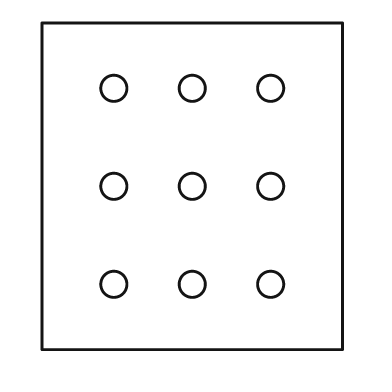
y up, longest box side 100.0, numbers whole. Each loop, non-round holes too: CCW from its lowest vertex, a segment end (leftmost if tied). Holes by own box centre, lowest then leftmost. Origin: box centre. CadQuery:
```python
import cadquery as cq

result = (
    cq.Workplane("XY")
    .moveTo(-46.0, -50.0)
    .lineTo(46.0, -50.0)
    .lineTo(46.0, 50.0)
    .lineTo(-46.0, 50.0)
    .close()
    .moveTo(-24.0, -30.0)
    .circle(4.0)
    .moveTo(0.0, -30.0)
    .circle(4.0)
    .moveTo(24.0, -30.0)
    .circle(4.0)
    .moveTo(-24.0, 0.0)
    .circle(4.0)
    .moveTo(0.0, 0.0)
    .circle(4.0)
    .moveTo(24.0, 0.0)
    .circle(4.0)
    .moveTo(-24.0, 30.0)
    .circle(4.0)
    .moveTo(0.0, 30.0)
    .circle(4.0)
    .moveTo(24.0, 30.0)
    .circle(4.0)
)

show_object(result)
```